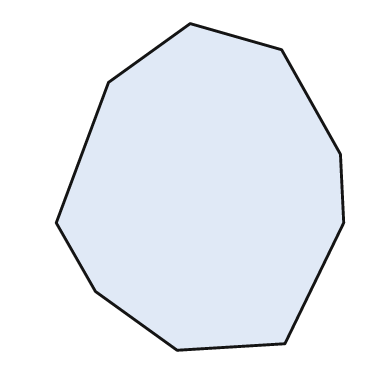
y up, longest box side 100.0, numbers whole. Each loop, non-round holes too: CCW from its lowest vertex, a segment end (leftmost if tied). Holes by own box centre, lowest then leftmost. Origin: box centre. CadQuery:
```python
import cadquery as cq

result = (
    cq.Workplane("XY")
    .moveTo(-7.0, -50.0)
    .lineTo(26.0, -48.0)
    .lineTo(44.0, -11.0)
    .lineTo(43.0, 10.0)
    .lineTo(25.0, 42.0)
    .lineTo(-3.0, 50.0)
    .lineTo(-28.0, 32.0)
    .lineTo(-44.0, -11.0)
    .lineTo(-32.0, -32.0)
    .close()
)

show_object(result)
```